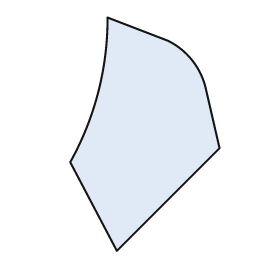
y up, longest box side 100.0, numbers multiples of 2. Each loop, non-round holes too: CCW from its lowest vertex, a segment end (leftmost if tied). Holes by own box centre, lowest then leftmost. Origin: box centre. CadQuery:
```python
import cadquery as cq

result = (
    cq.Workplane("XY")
    .moveTo(-12.0, -50.0)
    .lineTo(32.0, -6.0)
    .lineTo(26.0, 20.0)
    .threePointArc((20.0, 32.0), (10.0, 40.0))
    .lineTo(-16.0, 50.0)
    .threePointArc((-20.0, 18.0), (-32.0, -12.0))
    .close()
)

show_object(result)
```